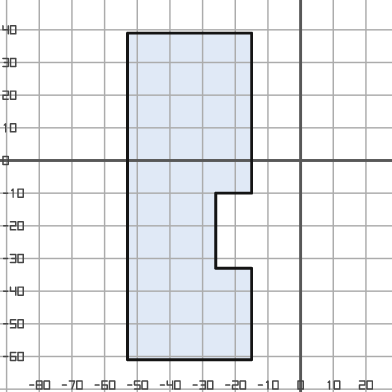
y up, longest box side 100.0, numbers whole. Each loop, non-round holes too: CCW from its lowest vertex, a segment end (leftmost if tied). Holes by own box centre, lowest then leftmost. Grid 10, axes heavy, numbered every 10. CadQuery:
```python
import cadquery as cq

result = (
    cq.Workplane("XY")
    .moveTo(-53.0, -61.0)
    .lineTo(-15.0, -61.0)
    .lineTo(-15.0, -33.0)
    .lineTo(-26.0, -33.0)
    .lineTo(-26.0, -10.0)
    .lineTo(-15.0, -10.0)
    .lineTo(-15.0, 39.0)
    .lineTo(-53.0, 39.0)
    .close()
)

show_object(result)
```